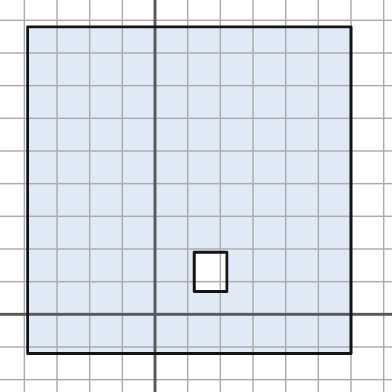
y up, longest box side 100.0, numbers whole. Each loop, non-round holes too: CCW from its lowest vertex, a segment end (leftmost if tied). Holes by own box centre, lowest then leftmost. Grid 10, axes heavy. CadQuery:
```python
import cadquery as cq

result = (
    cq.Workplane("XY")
    .moveTo(-39.0, -12.0)
    .lineTo(60.0, -12.0)
    .lineTo(60.0, 88.0)
    .lineTo(-39.0, 88.0)
    .close()
    .moveTo(12.0, 7.0)
    .lineTo(22.0, 7.0)
    .lineTo(22.0, 19.0)
    .lineTo(12.0, 19.0)
    .close()
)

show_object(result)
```